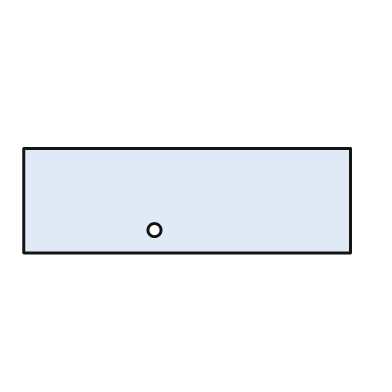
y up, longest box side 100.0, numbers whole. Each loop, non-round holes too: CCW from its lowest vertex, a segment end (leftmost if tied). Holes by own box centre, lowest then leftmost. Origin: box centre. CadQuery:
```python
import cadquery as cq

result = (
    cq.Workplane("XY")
    .moveTo(-50.0, -16.0)
    .lineTo(50.0, -16.0)
    .lineTo(50.0, 16.0)
    .lineTo(-50.0, 16.0)
    .close()
    .moveTo(-10.0, -9.0)
    .circle(2.0)
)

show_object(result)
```